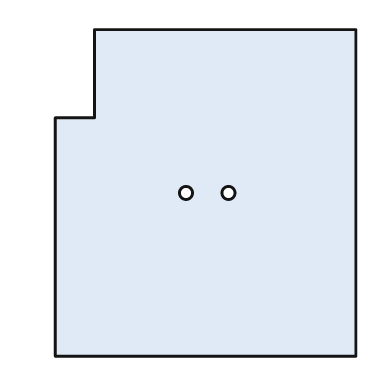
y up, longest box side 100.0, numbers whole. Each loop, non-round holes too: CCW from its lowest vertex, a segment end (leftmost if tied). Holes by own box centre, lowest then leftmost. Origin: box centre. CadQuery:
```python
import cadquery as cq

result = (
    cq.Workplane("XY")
    .moveTo(-46.0, -50.0)
    .lineTo(46.0, -50.0)
    .lineTo(46.0, 50.0)
    .lineTo(-34.0, 50.0)
    .lineTo(-34.0, 23.0)
    .lineTo(-46.0, 23.0)
    .close()
    .moveTo(-6.0, 0.0)
    .circle(2.0)
    .moveTo(7.0, 0.0)
    .circle(2.0)
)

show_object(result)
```